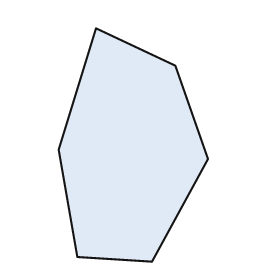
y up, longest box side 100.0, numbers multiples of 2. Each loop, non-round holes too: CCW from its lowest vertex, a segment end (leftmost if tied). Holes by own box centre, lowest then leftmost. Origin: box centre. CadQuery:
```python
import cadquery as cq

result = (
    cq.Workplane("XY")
    .moveTo(8.0, -50.0)
    .lineTo(32.0, -6.0)
    .lineTo(18.0, 34.0)
    .lineTo(-16.0, 50.0)
    .lineTo(-32.0, -2.0)
    .lineTo(-24.0, -48.0)
    .close()
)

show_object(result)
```